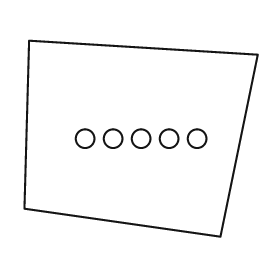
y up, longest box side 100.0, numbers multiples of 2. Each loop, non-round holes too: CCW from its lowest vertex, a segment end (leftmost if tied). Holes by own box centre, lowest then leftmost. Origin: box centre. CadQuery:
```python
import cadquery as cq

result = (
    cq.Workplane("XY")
    .moveTo(34.0, -42.0)
    .lineTo(50.0, 36.0)
    .lineTo(-48.0, 42.0)
    .lineTo(-50.0, -30.0)
    .close()
    .moveTo(-24.0, 0.0)
    .circle(4.0)
    .moveTo(-12.0, 0.0)
    .circle(4.0)
    .moveTo(0.0, 0.0)
    .circle(4.0)
    .moveTo(12.0, 0.0)
    .circle(4.0)
    .moveTo(24.0, 0.0)
    .circle(4.0)
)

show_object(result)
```